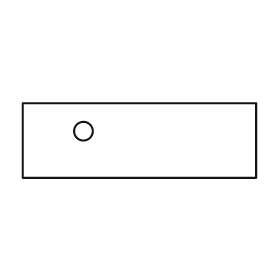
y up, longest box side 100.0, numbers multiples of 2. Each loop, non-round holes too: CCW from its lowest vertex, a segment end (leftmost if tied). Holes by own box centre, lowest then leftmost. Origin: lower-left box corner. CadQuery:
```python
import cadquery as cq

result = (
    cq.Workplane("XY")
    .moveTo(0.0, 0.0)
    .lineTo(100.0, 0.0)
    .lineTo(100.0, 32.0)
    .lineTo(0.0, 32.0)
    .close()
    .moveTo(26.0, 20.0)
    .circle(4.0)
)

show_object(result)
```